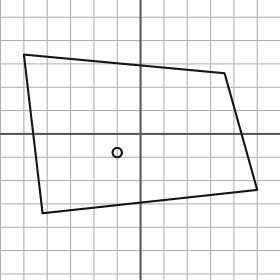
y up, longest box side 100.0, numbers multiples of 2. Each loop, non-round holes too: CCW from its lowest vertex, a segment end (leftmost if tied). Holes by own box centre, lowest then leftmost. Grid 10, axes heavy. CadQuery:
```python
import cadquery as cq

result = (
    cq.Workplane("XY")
    .moveTo(-42.0, -34.0)
    .lineTo(50.0, -24.0)
    .lineTo(36.0, 26.0)
    .lineTo(-50.0, 34.0)
    .close()
    .moveTo(-10.0, -8.0)
    .circle(2.0)
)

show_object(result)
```